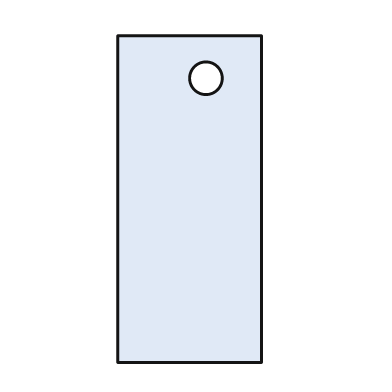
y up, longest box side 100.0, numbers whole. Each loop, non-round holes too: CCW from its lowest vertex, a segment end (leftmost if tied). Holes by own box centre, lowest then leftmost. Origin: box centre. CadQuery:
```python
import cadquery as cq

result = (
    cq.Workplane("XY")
    .moveTo(-22.0, -50.0)
    .lineTo(22.0, -50.0)
    .lineTo(22.0, 50.0)
    .lineTo(-22.0, 50.0)
    .close()
    .moveTo(5.0, 37.0)
    .circle(5.0)
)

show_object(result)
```